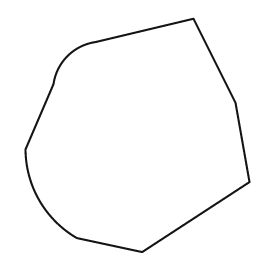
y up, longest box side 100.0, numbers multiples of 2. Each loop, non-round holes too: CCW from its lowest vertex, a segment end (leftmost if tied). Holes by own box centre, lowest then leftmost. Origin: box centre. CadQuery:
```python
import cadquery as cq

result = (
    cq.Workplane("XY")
    .moveTo(2.0, -50.0)
    .lineTo(48.0, -20.0)
    .lineTo(42.0, 14.0)
    .lineTo(24.0, 50.0)
    .lineTo(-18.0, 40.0)
    .threePointArc((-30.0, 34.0), (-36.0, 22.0))
    .lineTo(-48.0, -6.0)
    .threePointArc((-42.0, -28.0), (-26.0, -44.0))
    .close()
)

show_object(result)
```